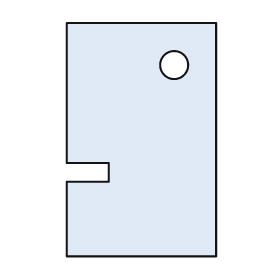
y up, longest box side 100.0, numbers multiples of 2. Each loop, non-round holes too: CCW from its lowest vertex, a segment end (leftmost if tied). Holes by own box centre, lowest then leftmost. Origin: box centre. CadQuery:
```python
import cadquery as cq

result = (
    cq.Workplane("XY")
    .moveTo(-32.0, -50.0)
    .lineTo(32.0, -50.0)
    .lineTo(32.0, 50.0)
    .lineTo(-32.0, 50.0)
    .lineTo(-32.0, -10.0)
    .lineTo(-14.0, -10.0)
    .lineTo(-14.0, -18.0)
    .lineTo(-32.0, -18.0)
    .close()
    .moveTo(14.0, 32.0)
    .circle(6.0)
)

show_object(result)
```